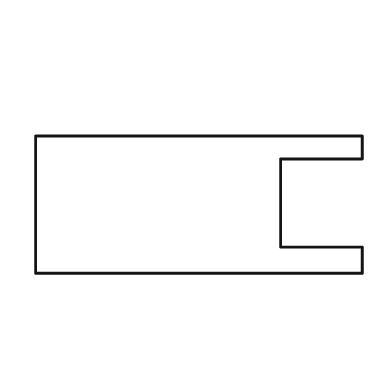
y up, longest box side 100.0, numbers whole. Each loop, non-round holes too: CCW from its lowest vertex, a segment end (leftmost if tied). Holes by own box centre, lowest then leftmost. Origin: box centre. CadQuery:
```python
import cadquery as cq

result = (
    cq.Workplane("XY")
    .moveTo(-50.0, -21.0)
    .lineTo(50.0, -21.0)
    .lineTo(50.0, -13.0)
    .lineTo(25.0, -13.0)
    .lineTo(25.0, 14.0)
    .lineTo(50.0, 14.0)
    .lineTo(50.0, 21.0)
    .lineTo(-50.0, 21.0)
    .close()
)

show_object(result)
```